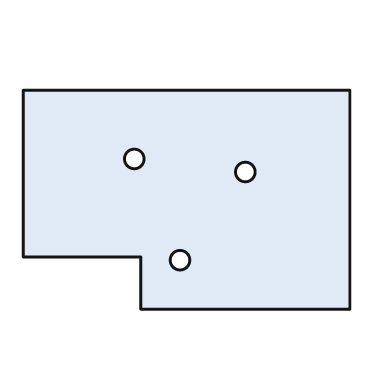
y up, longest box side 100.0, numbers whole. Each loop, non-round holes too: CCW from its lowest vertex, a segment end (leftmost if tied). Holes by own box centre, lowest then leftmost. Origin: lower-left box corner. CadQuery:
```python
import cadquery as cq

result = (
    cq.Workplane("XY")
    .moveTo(36.0, 0.0)
    .lineTo(100.0, 0.0)
    .lineTo(100.0, 67.0)
    .lineTo(0.0, 67.0)
    .lineTo(0.0, 16.0)
    .lineTo(36.0, 16.0)
    .close()
    .moveTo(48.0, 15.0)
    .circle(3.0)
    .moveTo(68.0, 42.0)
    .circle(3.0)
    .moveTo(34.0, 46.0)
    .circle(3.0)
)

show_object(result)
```